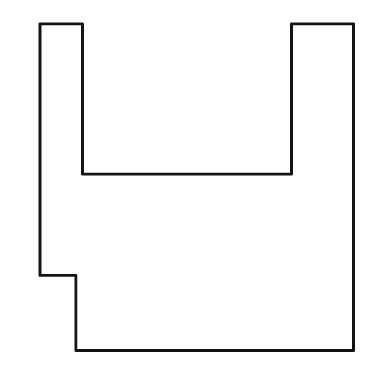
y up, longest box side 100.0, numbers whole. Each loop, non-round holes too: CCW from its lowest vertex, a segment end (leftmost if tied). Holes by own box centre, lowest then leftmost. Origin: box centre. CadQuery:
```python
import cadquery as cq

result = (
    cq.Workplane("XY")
    .moveTo(-37.0, -50.0)
    .lineTo(48.0, -50.0)
    .lineTo(48.0, 50.0)
    .lineTo(29.0, 50.0)
    .lineTo(29.0, 4.0)
    .lineTo(-35.0, 4.0)
    .lineTo(-35.0, 50.0)
    .lineTo(-48.0, 50.0)
    .lineTo(-48.0, -27.0)
    .lineTo(-37.0, -27.0)
    .close()
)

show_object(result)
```